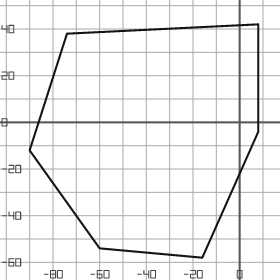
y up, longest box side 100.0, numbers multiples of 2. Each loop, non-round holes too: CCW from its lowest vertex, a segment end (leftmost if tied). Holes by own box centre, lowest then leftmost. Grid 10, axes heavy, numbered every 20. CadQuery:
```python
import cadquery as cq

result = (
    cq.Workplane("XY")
    .moveTo(-16.0, -58.0)
    .lineTo(8.0, -4.0)
    .lineTo(8.0, 42.0)
    .lineTo(-74.0, 38.0)
    .lineTo(-90.0, -12.0)
    .lineTo(-60.0, -54.0)
    .close()
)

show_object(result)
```